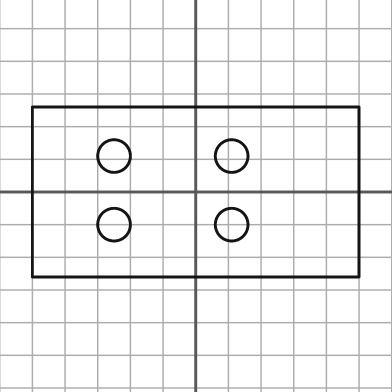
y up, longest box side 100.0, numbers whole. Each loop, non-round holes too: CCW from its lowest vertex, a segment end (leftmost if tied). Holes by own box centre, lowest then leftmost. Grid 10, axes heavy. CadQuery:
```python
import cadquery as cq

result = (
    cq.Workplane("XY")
    .moveTo(-50.0, -26.0)
    .lineTo(50.0, -26.0)
    .lineTo(50.0, 26.0)
    .lineTo(-50.0, 26.0)
    .close()
    .moveTo(-25.0, -10.0)
    .circle(5.0)
    .moveTo(11.0, -10.0)
    .circle(5.0)
    .moveTo(-25.0, 11.0)
    .circle(5.0)
    .moveTo(11.0, 11.0)
    .circle(5.0)
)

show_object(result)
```